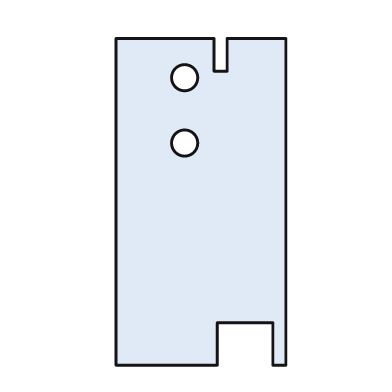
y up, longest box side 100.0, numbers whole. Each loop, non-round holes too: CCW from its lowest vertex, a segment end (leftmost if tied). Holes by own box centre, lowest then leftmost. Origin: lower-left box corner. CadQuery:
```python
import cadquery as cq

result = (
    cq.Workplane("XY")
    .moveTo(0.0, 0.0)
    .lineTo(31.0, 0.0)
    .lineTo(31.0, 13.0)
    .lineTo(48.0, 13.0)
    .lineTo(48.0, 0.0)
    .lineTo(52.0, 0.0)
    .lineTo(52.0, 100.0)
    .lineTo(34.0, 100.0)
    .lineTo(34.0, 90.0)
    .lineTo(30.0, 90.0)
    .lineTo(30.0, 100.0)
    .lineTo(0.0, 100.0)
    .close()
    .moveTo(21.0, 68.0)
    .circle(4.0)
    .moveTo(21.0, 88.0)
    .circle(4.0)
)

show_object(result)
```